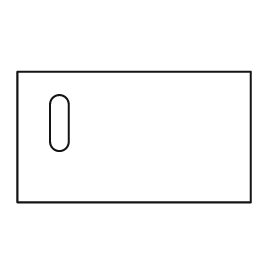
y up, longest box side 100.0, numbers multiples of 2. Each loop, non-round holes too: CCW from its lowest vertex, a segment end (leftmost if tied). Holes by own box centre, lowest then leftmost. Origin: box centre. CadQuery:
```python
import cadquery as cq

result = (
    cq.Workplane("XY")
    .moveTo(-50.0, -28.0)
    .lineTo(50.0, -28.0)
    .lineTo(50.0, 28.0)
    .lineTo(-50.0, 28.0)
    .close()
    .moveTo(-36.0, -2.0)
    .threePointArc((-32.0, -6.0), (-28.0, -2.0))
    .lineTo(-28.0, 14.0)
    .threePointArc((-32.0, 18.0), (-36.0, 14.0))
    .close()
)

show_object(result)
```